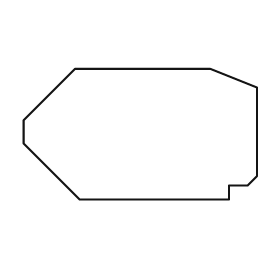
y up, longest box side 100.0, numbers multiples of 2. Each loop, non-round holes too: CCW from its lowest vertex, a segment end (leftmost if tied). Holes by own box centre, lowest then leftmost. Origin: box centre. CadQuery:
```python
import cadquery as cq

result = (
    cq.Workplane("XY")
    .moveTo(-26.0, -28.0)
    .lineTo(38.0, -28.0)
    .lineTo(38.0, -22.0)
    .lineTo(46.0, -22.0)
    .lineTo(50.0, -18.0)
    .lineTo(50.0, 20.0)
    .lineTo(30.0, 28.0)
    .lineTo(-28.0, 28.0)
    .lineTo(-50.0, 6.0)
    .lineTo(-50.0, -4.0)
    .close()
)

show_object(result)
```